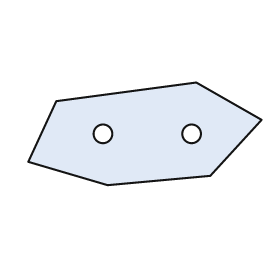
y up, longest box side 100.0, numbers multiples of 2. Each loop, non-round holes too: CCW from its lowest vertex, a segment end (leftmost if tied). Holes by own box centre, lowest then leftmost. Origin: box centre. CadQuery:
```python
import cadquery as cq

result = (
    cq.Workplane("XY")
    .moveTo(-16.0, -22.0)
    .lineTo(28.0, -18.0)
    .lineTo(50.0, 6.0)
    .lineTo(22.0, 22.0)
    .lineTo(-38.0, 14.0)
    .lineTo(-50.0, -12.0)
    .close()
    .moveTo(-18.0, 0.0)
    .circle(4.0)
    .moveTo(20.0, 0.0)
    .circle(4.0)
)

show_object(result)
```